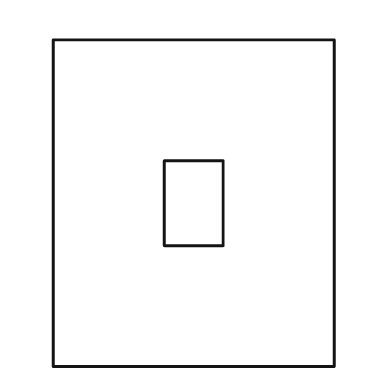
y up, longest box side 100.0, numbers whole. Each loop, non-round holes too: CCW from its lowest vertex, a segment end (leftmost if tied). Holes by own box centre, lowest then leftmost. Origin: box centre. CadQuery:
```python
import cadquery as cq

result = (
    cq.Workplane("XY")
    .moveTo(-43.0, -50.0)
    .lineTo(43.0, -50.0)
    .lineTo(43.0, 50.0)
    .lineTo(-43.0, 50.0)
    .close()
    .moveTo(-9.0, -13.0)
    .lineTo(9.0, -13.0)
    .lineTo(9.0, 13.0)
    .lineTo(-9.0, 13.0)
    .close()
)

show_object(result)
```